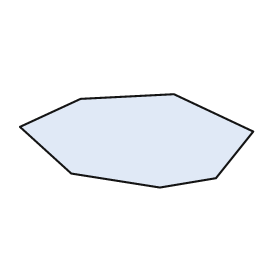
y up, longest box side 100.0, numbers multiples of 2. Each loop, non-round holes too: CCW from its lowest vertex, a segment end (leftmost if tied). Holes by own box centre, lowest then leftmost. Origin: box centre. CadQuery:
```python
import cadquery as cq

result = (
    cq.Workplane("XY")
    .moveTo(10.0, -20.0)
    .lineTo(34.0, -16.0)
    .lineTo(50.0, 4.0)
    .lineTo(16.0, 20.0)
    .lineTo(-24.0, 18.0)
    .lineTo(-50.0, 6.0)
    .lineTo(-28.0, -14.0)
    .close()
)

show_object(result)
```